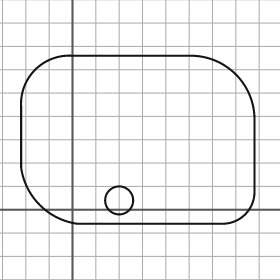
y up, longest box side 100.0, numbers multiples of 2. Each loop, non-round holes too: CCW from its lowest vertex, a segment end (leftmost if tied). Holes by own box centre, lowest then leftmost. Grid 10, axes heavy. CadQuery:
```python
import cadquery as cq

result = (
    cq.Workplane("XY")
    .moveTo(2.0, -6.0)
    .lineTo(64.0, -6.0)
    .threePointArc((74.0, -2.0), (78.0, 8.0))
    .lineTo(78.0, 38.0)
    .threePointArc((70.0, 58.0), (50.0, 66.0))
    .lineTo(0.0, 66.0)
    .threePointArc((-16.0, 60.0), (-22.0, 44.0))
    .lineTo(-22.0, 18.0)
    .threePointArc((-14.0, 2.0), (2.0, -6.0))
    .close()
    .moveTo(20.0, 4.0)
    .circle(6.0)
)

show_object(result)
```